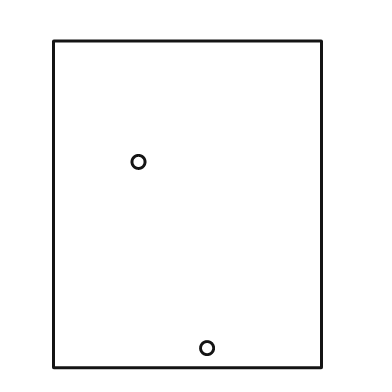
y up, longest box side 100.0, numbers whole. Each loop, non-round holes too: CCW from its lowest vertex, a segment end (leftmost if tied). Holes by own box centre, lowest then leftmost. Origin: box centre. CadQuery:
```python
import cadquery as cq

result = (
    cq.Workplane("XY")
    .moveTo(-41.0, -50.0)
    .lineTo(41.0, -50.0)
    .lineTo(41.0, 50.0)
    .lineTo(-41.0, 50.0)
    .close()
    .moveTo(6.0, -44.0)
    .circle(2.0)
    .moveTo(-15.0, 13.0)
    .circle(2.0)
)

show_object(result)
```